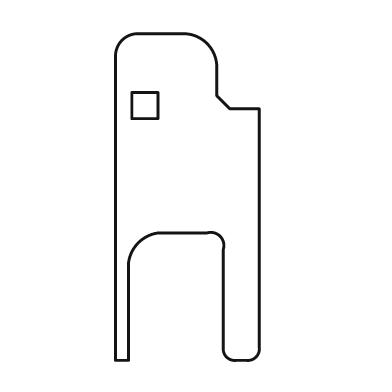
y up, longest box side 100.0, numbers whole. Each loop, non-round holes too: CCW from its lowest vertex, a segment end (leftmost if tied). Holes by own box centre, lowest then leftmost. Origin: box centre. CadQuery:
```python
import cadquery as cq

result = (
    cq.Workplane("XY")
    .moveTo(-22.0, -50.0)
    .lineTo(-18.0, -50.0)
    .lineTo(-18.0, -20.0)
    .threePointArc((-15.0, -14.0), (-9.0, -11.0))
    .lineTo(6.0, -11.0)
    .threePointArc((10.0, -12.0), (11.0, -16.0))
    .lineTo(11.0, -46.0)
    .threePointArc((12.0, -49.0), (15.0, -50.0))
    .lineTo(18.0, -50.0)
    .threePointArc((21.0, -49.0), (22.0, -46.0))
    .lineTo(22.0, 27.0)
    .lineTo(13.0, 27.0)
    .lineTo(9.0, 31.0)
    .lineTo(9.0, 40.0)
    .threePointArc((6.0, 47.0), (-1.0, 50.0))
    .lineTo(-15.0, 50.0)
    .threePointArc((-20.0, 48.0), (-22.0, 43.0))
    .close()
    .moveTo(-17.0, 24.0)
    .lineTo(-9.0, 24.0)
    .lineTo(-9.0, 32.0)
    .lineTo(-17.0, 32.0)
    .close()
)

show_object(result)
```